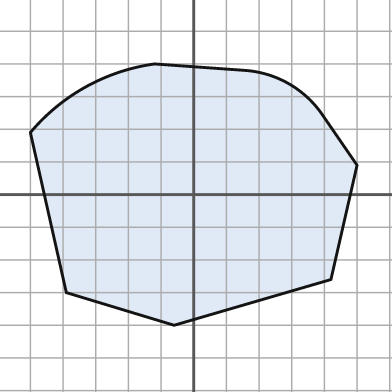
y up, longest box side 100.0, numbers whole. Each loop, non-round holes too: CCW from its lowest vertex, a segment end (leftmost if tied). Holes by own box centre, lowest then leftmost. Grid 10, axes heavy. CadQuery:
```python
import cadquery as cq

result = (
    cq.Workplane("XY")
    .moveTo(-6.0, -40.0)
    .lineTo(42.0, -26.0)
    .lineTo(50.0, 9.0)
    .lineTo(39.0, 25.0)
    .threePointArc((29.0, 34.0), (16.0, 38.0))
    .lineTo(-12.0, 40.0)
    .threePointArc((-33.0, 33.0), (-50.0, 19.0))
    .lineTo(-39.0, -30.0)
    .close()
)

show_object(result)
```